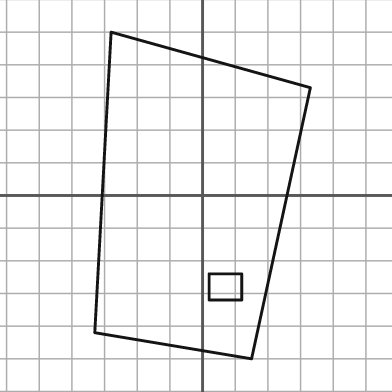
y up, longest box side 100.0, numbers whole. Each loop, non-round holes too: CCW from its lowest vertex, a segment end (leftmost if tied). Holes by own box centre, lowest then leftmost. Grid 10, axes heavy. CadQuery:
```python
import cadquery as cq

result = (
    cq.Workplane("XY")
    .moveTo(15.0, -50.0)
    .lineTo(33.0, 33.0)
    .lineTo(-28.0, 50.0)
    .lineTo(-33.0, -42.0)
    .close()
    .moveTo(2.0, -32.0)
    .lineTo(12.0, -32.0)
    .lineTo(12.0, -24.0)
    .lineTo(2.0, -24.0)
    .close()
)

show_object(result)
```